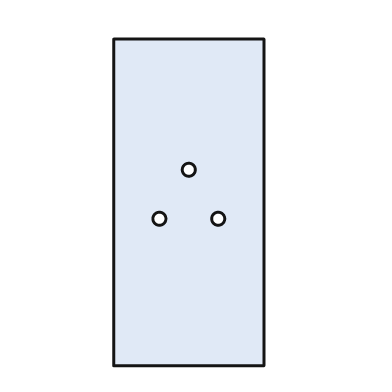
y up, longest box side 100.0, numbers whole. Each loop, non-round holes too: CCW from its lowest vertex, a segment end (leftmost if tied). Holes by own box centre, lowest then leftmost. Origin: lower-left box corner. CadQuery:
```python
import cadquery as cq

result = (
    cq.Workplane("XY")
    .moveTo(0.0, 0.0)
    .lineTo(46.0, 0.0)
    .lineTo(46.0, 100.0)
    .lineTo(0.0, 100.0)
    .close()
    .moveTo(14.0, 45.0)
    .circle(2.0)
    .moveTo(32.0, 45.0)
    .circle(2.0)
    .moveTo(23.0, 60.0)
    .circle(2.0)
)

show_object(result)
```